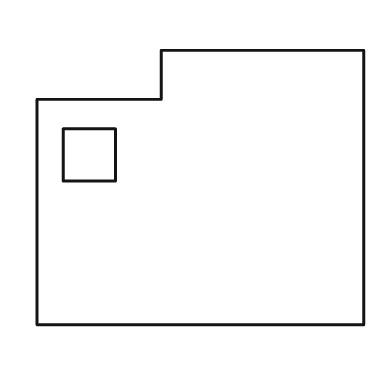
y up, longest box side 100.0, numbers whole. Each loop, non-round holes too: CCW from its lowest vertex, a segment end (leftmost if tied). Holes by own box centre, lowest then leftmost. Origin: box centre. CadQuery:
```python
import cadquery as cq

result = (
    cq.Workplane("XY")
    .moveTo(-50.0, -42.0)
    .lineTo(50.0, -42.0)
    .lineTo(50.0, 42.0)
    .lineTo(-12.0, 42.0)
    .lineTo(-12.0, 27.0)
    .lineTo(-50.0, 27.0)
    .close()
    .moveTo(-42.0, 2.0)
    .lineTo(-26.0, 2.0)
    .lineTo(-26.0, 18.0)
    .lineTo(-42.0, 18.0)
    .close()
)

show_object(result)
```